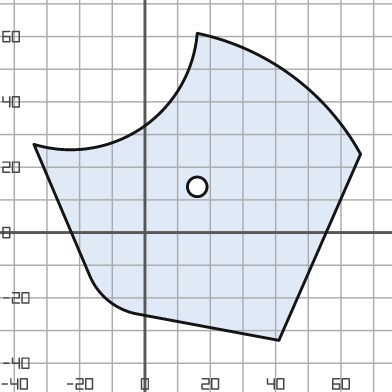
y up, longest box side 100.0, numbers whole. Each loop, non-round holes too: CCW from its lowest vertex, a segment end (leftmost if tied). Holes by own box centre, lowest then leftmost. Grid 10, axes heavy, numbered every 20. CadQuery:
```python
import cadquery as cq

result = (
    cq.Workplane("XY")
    .moveTo(41.0, -33.0)
    .lineTo(66.0, 24.0)
    .threePointArc((45.0, 48.0), (16.0, 61.0))
    .threePointArc((-1.0, 32.0), (-34.0, 27.0))
    .lineTo(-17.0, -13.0)
    .threePointArc((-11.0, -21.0), (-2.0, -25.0))
    .close()
    .moveTo(16.0, 14.0)
    .circle(3.0)
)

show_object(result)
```